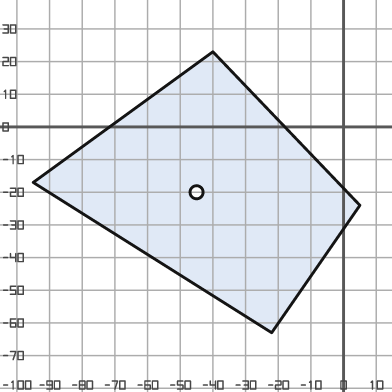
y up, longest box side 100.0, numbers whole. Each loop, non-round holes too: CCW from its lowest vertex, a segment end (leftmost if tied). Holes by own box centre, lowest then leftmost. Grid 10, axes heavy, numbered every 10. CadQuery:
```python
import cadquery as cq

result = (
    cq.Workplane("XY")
    .moveTo(-22.0, -63.0)
    .lineTo(5.0, -24.0)
    .lineTo(-40.0, 23.0)
    .lineTo(-95.0, -17.0)
    .close()
    .moveTo(-45.0, -20.0)
    .circle(2.0)
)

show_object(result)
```